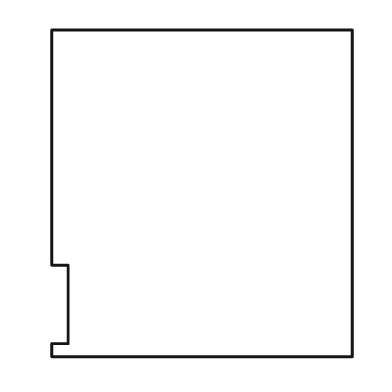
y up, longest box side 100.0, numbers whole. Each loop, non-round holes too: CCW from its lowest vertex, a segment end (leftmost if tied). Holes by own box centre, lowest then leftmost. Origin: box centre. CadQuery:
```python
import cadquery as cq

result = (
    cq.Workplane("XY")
    .moveTo(-46.0, -50.0)
    .lineTo(46.0, -50.0)
    .lineTo(46.0, 50.0)
    .lineTo(-46.0, 50.0)
    .lineTo(-46.0, -22.0)
    .lineTo(-41.0, -22.0)
    .lineTo(-41.0, -46.0)
    .lineTo(-46.0, -46.0)
    .close()
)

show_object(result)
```